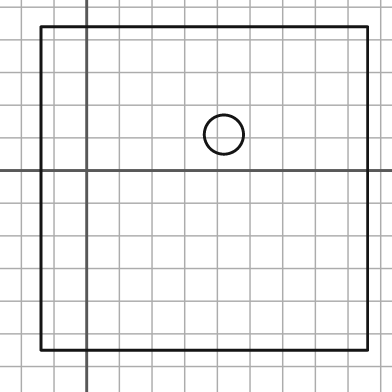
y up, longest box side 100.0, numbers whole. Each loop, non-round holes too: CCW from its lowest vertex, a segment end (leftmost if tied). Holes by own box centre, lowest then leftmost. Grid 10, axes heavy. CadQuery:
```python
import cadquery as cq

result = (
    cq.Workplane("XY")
    .moveTo(-14.0, -55.0)
    .lineTo(86.0, -55.0)
    .lineTo(86.0, 44.0)
    .lineTo(-14.0, 44.0)
    .close()
    .moveTo(42.0, 11.0)
    .circle(6.0)
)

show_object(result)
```